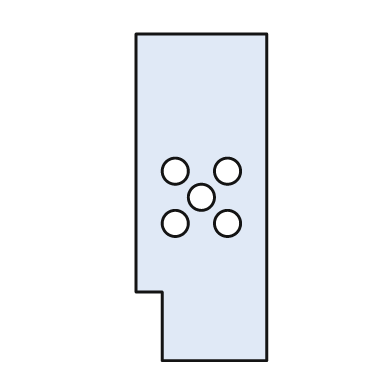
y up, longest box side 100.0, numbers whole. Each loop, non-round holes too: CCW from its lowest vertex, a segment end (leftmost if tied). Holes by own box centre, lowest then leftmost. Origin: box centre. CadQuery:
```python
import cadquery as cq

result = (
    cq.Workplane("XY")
    .moveTo(-12.0, -50.0)
    .lineTo(20.0, -50.0)
    .lineTo(20.0, 50.0)
    .lineTo(-20.0, 50.0)
    .lineTo(-20.0, -29.0)
    .lineTo(-12.0, -29.0)
    .close()
    .moveTo(-8.0, -8.0)
    .circle(4.0)
    .moveTo(8.0, -8.0)
    .circle(4.0)
    .moveTo(0.0, 0.0)
    .circle(4.0)
    .moveTo(-8.0, 8.0)
    .circle(4.0)
    .moveTo(8.0, 8.0)
    .circle(4.0)
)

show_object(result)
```